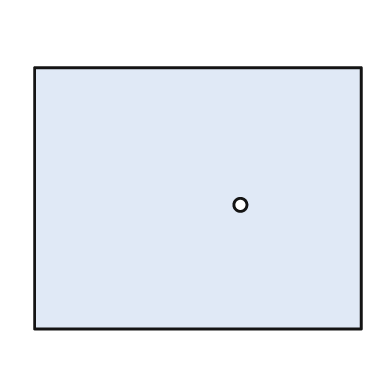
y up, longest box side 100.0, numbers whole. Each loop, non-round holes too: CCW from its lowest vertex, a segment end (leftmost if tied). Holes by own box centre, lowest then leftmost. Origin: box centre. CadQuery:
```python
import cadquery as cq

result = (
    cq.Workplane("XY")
    .moveTo(-50.0, -40.0)
    .lineTo(50.0, -40.0)
    .lineTo(50.0, 40.0)
    .lineTo(-50.0, 40.0)
    .close()
    .moveTo(13.0, -2.0)
    .circle(2.0)
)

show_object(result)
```